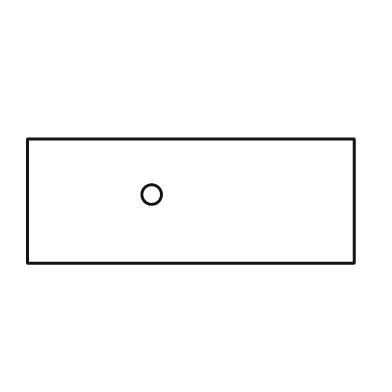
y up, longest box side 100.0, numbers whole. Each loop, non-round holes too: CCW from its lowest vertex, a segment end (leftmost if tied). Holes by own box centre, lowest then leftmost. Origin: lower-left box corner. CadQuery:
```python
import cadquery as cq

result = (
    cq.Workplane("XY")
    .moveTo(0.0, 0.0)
    .lineTo(100.0, 0.0)
    .lineTo(100.0, 38.0)
    .lineTo(0.0, 38.0)
    .close()
    .moveTo(38.0, 21.0)
    .circle(3.0)
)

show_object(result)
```